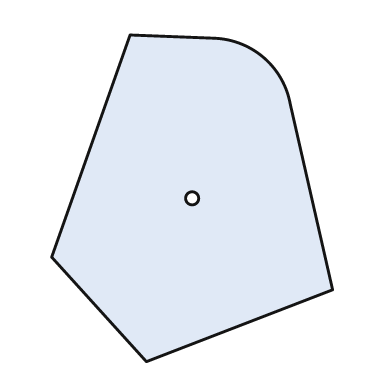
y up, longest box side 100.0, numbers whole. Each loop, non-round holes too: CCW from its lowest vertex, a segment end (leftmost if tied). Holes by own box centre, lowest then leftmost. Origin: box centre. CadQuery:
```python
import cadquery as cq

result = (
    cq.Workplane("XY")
    .moveTo(-14.0, -50.0)
    .lineTo(43.0, -28.0)
    .lineTo(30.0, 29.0)
    .threePointArc((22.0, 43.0), (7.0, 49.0))
    .lineTo(-19.0, 50.0)
    .lineTo(-43.0, -18.0)
    .close()
    .moveTo(0.0, 0.0)
    .circle(2.0)
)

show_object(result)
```